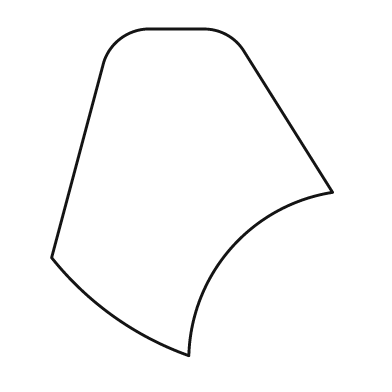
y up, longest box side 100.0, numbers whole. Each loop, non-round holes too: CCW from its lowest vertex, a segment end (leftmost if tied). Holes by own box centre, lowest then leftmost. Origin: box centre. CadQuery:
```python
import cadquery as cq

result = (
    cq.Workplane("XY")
    .moveTo(-1.0, -50.0)
    .threePointArc((12.0, -17.0), (43.0, 0.0))
    .lineTo(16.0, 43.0)
    .threePointArc((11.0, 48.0), (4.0, 50.0))
    .lineTo(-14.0, 50.0)
    .threePointArc((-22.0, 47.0), (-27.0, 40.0))
    .lineTo(-43.0, -20.0)
    .threePointArc((-24.0, -38.0), (-1.0, -50.0))
    .close()
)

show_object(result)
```